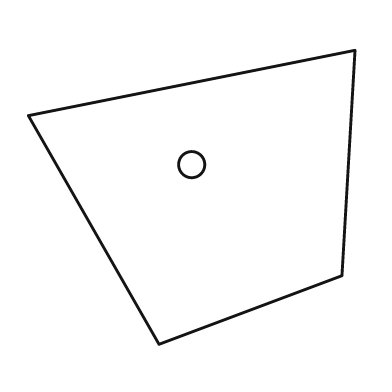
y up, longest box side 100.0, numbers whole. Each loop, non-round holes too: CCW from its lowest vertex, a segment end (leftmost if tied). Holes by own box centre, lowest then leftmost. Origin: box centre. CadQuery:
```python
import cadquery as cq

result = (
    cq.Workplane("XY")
    .moveTo(-10.0, -45.0)
    .lineTo(46.0, -24.0)
    .lineTo(50.0, 45.0)
    .lineTo(-50.0, 25.0)
    .close()
    .moveTo(0.0, 10.0)
    .circle(4.0)
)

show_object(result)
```